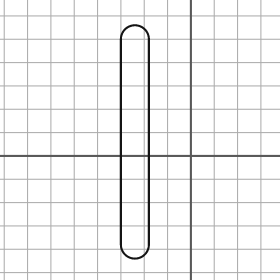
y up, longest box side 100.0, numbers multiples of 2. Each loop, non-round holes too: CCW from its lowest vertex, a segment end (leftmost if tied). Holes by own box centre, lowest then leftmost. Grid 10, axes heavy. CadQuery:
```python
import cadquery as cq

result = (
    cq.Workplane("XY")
    .moveTo(-30.0, -38.0)
    .threePointArc((-24.0, -44.0), (-18.0, -38.0))
    .lineTo(-18.0, 50.0)
    .threePointArc((-24.0, 56.0), (-30.0, 50.0))
    .close()
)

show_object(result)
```